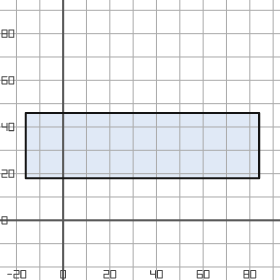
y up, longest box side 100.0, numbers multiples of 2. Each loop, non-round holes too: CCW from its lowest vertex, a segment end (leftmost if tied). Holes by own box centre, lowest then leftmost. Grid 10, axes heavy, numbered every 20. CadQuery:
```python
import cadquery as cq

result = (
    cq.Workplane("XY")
    .moveTo(-16.0, 18.0)
    .lineTo(84.0, 18.0)
    .lineTo(84.0, 46.0)
    .lineTo(-16.0, 46.0)
    .close()
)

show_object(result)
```